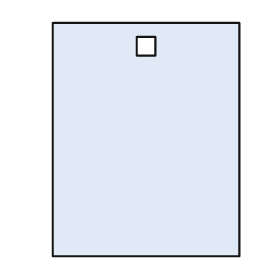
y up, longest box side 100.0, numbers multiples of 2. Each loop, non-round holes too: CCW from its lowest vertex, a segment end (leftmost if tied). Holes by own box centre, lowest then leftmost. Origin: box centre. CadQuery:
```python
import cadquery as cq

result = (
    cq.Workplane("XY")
    .moveTo(-40.0, -50.0)
    .lineTo(40.0, -50.0)
    .lineTo(40.0, 50.0)
    .lineTo(-40.0, 50.0)
    .close()
    .moveTo(-4.0, 36.0)
    .lineTo(4.0, 36.0)
    .lineTo(4.0, 44.0)
    .lineTo(-4.0, 44.0)
    .close()
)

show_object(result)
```